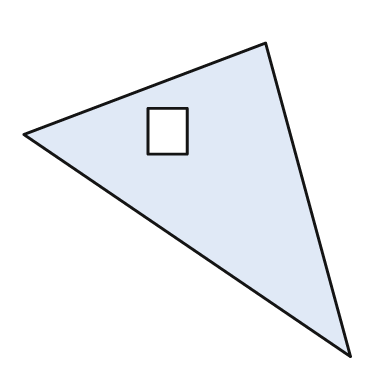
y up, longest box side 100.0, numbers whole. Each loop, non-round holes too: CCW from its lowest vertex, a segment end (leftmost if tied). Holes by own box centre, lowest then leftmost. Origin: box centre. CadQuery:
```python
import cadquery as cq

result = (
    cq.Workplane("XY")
    .moveTo(50.0, -48.0)
    .lineTo(24.0, 48.0)
    .lineTo(-50.0, 20.0)
    .close()
    .moveTo(-12.0, 14.0)
    .lineTo(0.0, 14.0)
    .lineTo(0.0, 28.0)
    .lineTo(-12.0, 28.0)
    .close()
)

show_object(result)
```